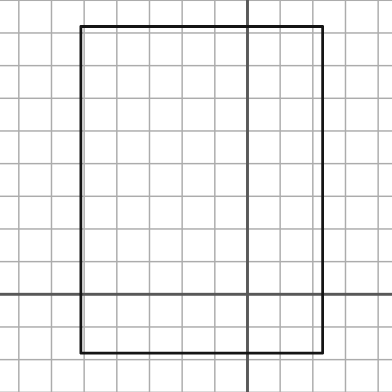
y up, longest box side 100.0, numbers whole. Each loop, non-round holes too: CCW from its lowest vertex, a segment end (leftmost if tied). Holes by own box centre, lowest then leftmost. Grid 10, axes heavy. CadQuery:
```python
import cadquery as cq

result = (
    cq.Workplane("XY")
    .moveTo(-51.0, -18.0)
    .lineTo(23.0, -18.0)
    .lineTo(23.0, 82.0)
    .lineTo(-51.0, 82.0)
    .close()
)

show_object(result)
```